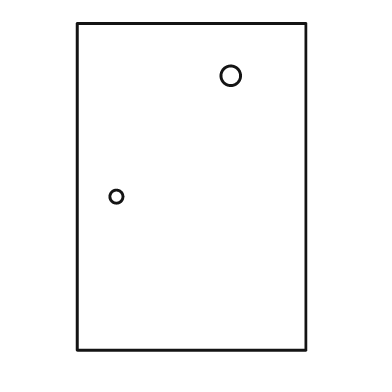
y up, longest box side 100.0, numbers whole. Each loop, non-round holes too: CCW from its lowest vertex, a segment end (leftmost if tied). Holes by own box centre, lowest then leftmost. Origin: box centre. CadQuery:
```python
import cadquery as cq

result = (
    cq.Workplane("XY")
    .moveTo(-35.0, -50.0)
    .lineTo(35.0, -50.0)
    .lineTo(35.0, 50.0)
    .lineTo(-35.0, 50.0)
    .close()
    .moveTo(-23.0, -3.0)
    .circle(2.0)
    .moveTo(12.0, 34.0)
    .circle(3.0)
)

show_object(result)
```